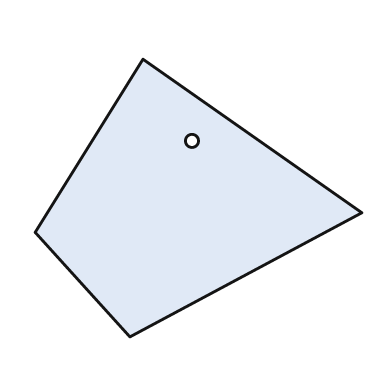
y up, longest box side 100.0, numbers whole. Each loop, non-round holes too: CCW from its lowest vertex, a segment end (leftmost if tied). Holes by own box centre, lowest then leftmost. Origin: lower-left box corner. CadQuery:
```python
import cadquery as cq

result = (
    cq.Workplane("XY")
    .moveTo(29.0, 0.0)
    .lineTo(100.0, 38.0)
    .lineTo(33.0, 85.0)
    .lineTo(0.0, 32.0)
    .close()
    .moveTo(48.0, 60.0)
    .circle(2.0)
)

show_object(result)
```